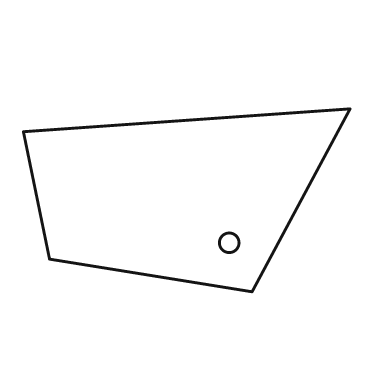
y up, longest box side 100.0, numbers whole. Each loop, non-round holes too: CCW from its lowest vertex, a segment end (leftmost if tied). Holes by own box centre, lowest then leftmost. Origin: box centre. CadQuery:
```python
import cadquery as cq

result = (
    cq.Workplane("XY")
    .moveTo(20.0, -28.0)
    .lineTo(50.0, 28.0)
    .lineTo(-50.0, 21.0)
    .lineTo(-42.0, -18.0)
    .close()
    .moveTo(13.0, -13.0)
    .circle(3.0)
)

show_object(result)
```